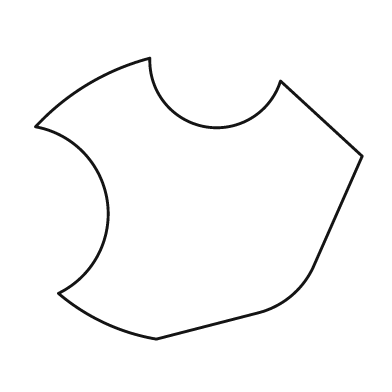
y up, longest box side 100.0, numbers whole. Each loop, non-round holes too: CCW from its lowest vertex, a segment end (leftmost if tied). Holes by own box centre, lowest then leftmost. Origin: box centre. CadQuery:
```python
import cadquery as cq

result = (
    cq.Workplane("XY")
    .moveTo(-13.0, -43.0)
    .lineTo(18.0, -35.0)
    .threePointArc((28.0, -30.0), (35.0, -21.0))
    .lineTo(50.0, 13.0)
    .lineTo(25.0, 36.0)
    .threePointArc((2.0, 22.0), (-15.0, 43.0))
    .threePointArc((-34.0, 35.0), (-50.0, 22.0))
    .threePointArc((-28.0, -1.0), (-43.0, -29.0))
    .threePointArc((-29.0, -38.0), (-13.0, -43.0))
    .close()
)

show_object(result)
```